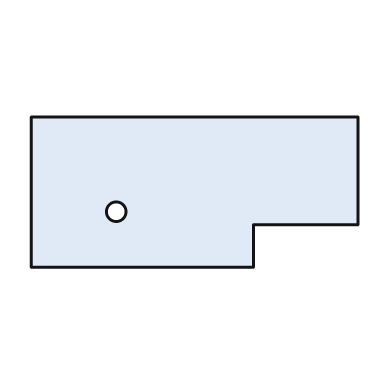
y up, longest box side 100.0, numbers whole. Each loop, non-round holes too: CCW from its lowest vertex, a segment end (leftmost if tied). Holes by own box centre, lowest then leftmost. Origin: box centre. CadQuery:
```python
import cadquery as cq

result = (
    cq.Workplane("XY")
    .moveTo(-50.0, -23.0)
    .lineTo(18.0, -23.0)
    .lineTo(18.0, -10.0)
    .lineTo(50.0, -10.0)
    .lineTo(50.0, 23.0)
    .lineTo(-50.0, 23.0)
    .close()
    .moveTo(-24.0, -6.0)
    .circle(3.0)
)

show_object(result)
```